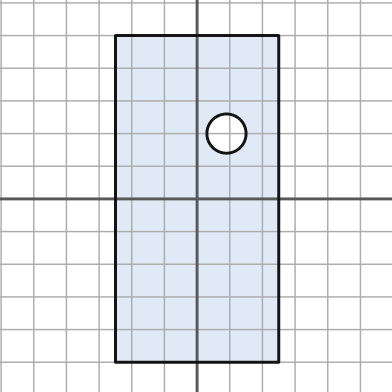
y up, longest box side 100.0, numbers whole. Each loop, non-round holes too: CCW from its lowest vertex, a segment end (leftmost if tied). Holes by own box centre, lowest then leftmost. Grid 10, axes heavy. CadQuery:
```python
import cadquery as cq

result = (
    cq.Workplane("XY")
    .moveTo(-25.0, -50.0)
    .lineTo(25.0, -50.0)
    .lineTo(25.0, 50.0)
    .lineTo(-25.0, 50.0)
    .close()
    .moveTo(9.0, 20.0)
    .circle(6.0)
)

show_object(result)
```